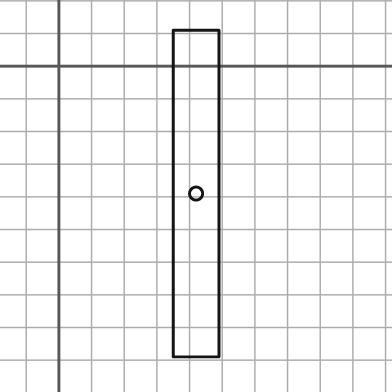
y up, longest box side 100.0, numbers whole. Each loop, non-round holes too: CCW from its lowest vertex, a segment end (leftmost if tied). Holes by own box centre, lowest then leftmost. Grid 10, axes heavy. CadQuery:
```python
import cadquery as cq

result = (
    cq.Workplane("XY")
    .moveTo(35.0, -89.0)
    .lineTo(49.0, -89.0)
    .lineTo(49.0, 11.0)
    .lineTo(35.0, 11.0)
    .close()
    .moveTo(42.0, -39.0)
    .circle(2.0)
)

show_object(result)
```